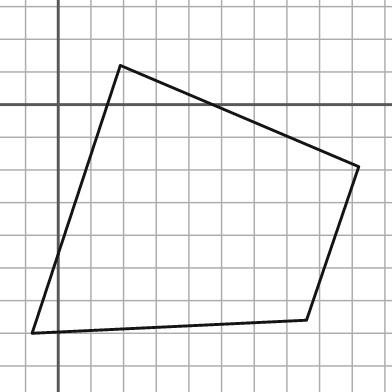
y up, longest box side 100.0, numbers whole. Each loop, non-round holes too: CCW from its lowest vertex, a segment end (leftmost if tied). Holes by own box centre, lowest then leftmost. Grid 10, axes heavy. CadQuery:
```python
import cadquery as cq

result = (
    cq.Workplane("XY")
    .moveTo(-8.0, -70.0)
    .lineTo(76.0, -66.0)
    .lineTo(92.0, -19.0)
    .lineTo(19.0, 12.0)
    .close()
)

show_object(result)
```